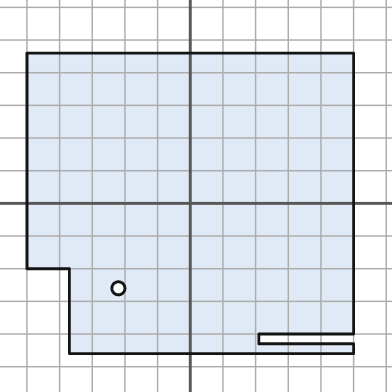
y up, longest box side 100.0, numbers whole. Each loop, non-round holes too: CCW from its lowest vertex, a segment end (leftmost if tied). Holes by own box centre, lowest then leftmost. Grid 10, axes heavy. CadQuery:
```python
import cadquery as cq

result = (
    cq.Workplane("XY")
    .moveTo(-37.0, -46.0)
    .lineTo(50.0, -46.0)
    .lineTo(50.0, -43.0)
    .lineTo(21.0, -43.0)
    .lineTo(21.0, -40.0)
    .lineTo(50.0, -40.0)
    .lineTo(50.0, 46.0)
    .lineTo(-50.0, 46.0)
    .lineTo(-50.0, -20.0)
    .lineTo(-37.0, -20.0)
    .close()
    .moveTo(-22.0, -26.0)
    .circle(2.0)
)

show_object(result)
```